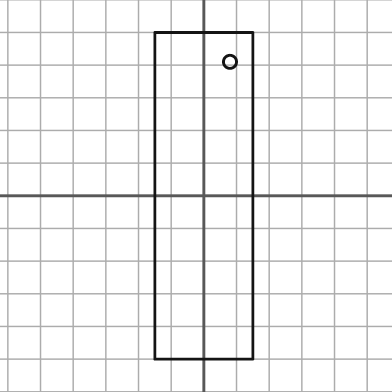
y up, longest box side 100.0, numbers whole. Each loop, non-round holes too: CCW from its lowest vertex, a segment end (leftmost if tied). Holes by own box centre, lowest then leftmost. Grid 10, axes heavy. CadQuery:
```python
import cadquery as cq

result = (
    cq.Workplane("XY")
    .moveTo(-15.0, -50.0)
    .lineTo(15.0, -50.0)
    .lineTo(15.0, 50.0)
    .lineTo(-15.0, 50.0)
    .close()
    .moveTo(8.0, 41.0)
    .circle(2.0)
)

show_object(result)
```